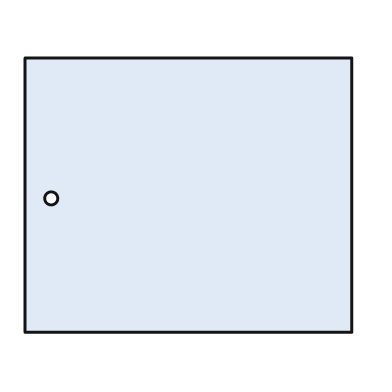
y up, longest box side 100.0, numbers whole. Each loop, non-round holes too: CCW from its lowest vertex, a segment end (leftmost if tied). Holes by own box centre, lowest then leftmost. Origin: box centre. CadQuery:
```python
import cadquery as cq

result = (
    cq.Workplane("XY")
    .moveTo(-50.0, -42.0)
    .lineTo(50.0, -42.0)
    .lineTo(50.0, 42.0)
    .lineTo(-50.0, 42.0)
    .close()
    .moveTo(-42.0, -1.0)
    .circle(2.0)
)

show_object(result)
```